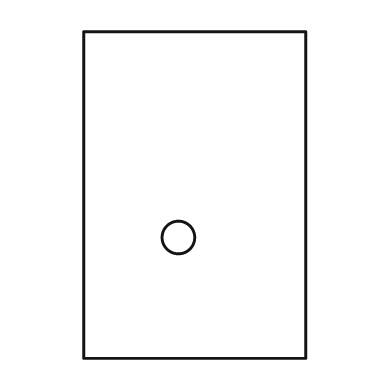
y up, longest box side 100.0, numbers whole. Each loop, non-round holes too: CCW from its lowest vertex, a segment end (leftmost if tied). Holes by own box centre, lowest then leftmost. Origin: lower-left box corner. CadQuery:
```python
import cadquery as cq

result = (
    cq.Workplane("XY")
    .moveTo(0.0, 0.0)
    .lineTo(68.0, 0.0)
    .lineTo(68.0, 100.0)
    .lineTo(0.0, 100.0)
    .close()
    .moveTo(29.0, 37.0)
    .circle(5.0)
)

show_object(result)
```